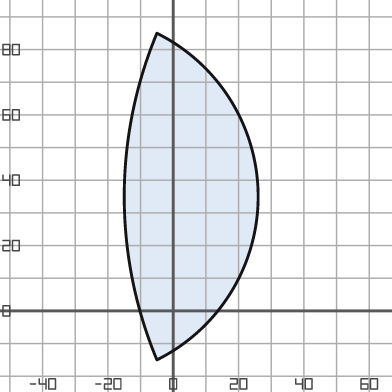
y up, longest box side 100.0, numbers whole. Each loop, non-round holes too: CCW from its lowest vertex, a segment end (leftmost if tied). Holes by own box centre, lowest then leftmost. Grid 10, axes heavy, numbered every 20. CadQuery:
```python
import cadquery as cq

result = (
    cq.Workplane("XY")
    .moveTo(-5.0, -15.0)
    .threePointArc((26.0, 35.0), (-5.0, 85.0))
    .threePointArc((-15.0, 35.0), (-5.0, -15.0))
    .close()
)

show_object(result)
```